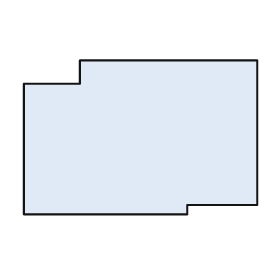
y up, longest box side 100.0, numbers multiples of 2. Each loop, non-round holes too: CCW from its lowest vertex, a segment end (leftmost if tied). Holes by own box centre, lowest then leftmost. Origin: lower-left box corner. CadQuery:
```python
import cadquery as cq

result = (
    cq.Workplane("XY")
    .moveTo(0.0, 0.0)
    .lineTo(70.0, 0.0)
    .lineTo(70.0, 4.0)
    .lineTo(100.0, 4.0)
    .lineTo(100.0, 66.0)
    .lineTo(24.0, 66.0)
    .lineTo(24.0, 56.0)
    .lineTo(0.0, 56.0)
    .close()
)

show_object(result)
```